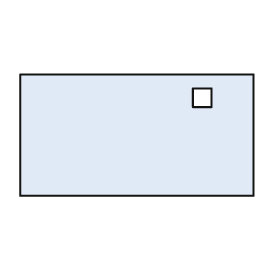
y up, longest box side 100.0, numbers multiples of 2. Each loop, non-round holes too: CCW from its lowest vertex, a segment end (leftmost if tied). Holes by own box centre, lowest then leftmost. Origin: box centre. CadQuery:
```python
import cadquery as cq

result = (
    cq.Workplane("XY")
    .moveTo(-50.0, -26.0)
    .lineTo(50.0, -26.0)
    .lineTo(50.0, 26.0)
    .lineTo(-50.0, 26.0)
    .close()
    .moveTo(24.0, 12.0)
    .lineTo(32.0, 12.0)
    .lineTo(32.0, 20.0)
    .lineTo(24.0, 20.0)
    .close()
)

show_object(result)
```